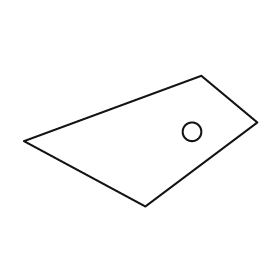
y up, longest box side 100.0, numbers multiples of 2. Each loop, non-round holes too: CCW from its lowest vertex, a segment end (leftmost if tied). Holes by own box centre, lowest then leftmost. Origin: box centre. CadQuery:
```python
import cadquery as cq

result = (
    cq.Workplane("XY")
    .moveTo(2.0, -28.0)
    .lineTo(50.0, 8.0)
    .lineTo(26.0, 28.0)
    .lineTo(-50.0, 0.0)
    .close()
    .moveTo(22.0, 4.0)
    .circle(4.0)
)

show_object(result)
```